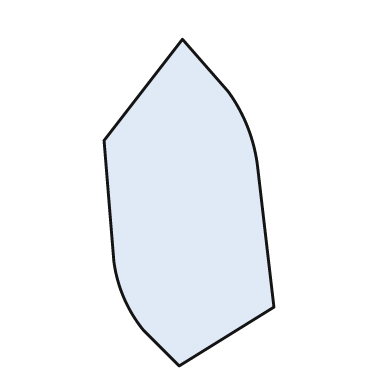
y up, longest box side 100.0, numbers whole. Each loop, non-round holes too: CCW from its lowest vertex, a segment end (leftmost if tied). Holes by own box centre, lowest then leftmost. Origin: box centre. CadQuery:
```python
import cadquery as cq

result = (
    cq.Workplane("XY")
    .moveTo(-3.0, -50.0)
    .lineTo(26.0, -32.0)
    .lineTo(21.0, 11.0)
    .threePointArc((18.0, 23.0), (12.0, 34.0))
    .lineTo(-2.0, 50.0)
    .lineTo(-26.0, 19.0)
    .lineTo(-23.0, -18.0)
    .threePointArc((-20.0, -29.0), (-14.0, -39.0))
    .close()
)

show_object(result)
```